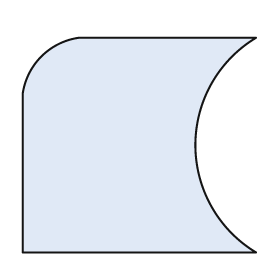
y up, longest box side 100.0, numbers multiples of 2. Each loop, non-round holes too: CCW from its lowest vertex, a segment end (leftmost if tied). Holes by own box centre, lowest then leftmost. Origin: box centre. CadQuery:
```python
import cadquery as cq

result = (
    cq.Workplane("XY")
    .moveTo(-50.0, -46.0)
    .lineTo(50.0, -46.0)
    .threePointArc((24.0, 0.0), (50.0, 46.0))
    .lineTo(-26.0, 46.0)
    .threePointArc((-42.0, 38.0), (-50.0, 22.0))
    .close()
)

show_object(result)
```